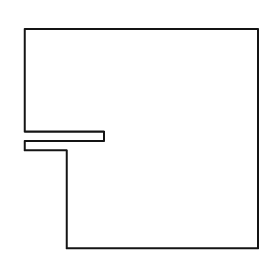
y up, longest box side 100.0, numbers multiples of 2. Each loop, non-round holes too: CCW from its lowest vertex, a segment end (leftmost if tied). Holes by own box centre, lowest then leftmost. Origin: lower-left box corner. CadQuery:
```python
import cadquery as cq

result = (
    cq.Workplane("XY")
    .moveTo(18.0, 0.0)
    .lineTo(100.0, 0.0)
    .lineTo(100.0, 94.0)
    .lineTo(0.0, 94.0)
    .lineTo(0.0, 50.0)
    .lineTo(34.0, 50.0)
    .lineTo(34.0, 46.0)
    .lineTo(0.0, 46.0)
    .lineTo(0.0, 42.0)
    .lineTo(18.0, 42.0)
    .close()
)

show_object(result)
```